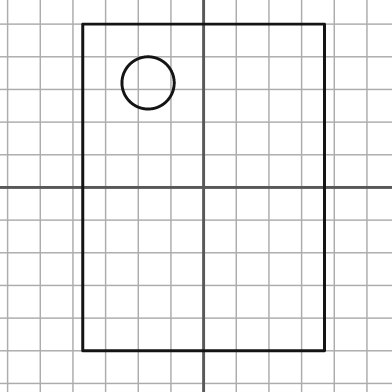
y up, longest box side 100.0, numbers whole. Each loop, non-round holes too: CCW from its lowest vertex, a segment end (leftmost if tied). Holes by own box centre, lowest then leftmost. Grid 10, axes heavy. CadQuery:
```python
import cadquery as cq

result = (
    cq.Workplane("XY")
    .moveTo(-37.0, -50.0)
    .lineTo(37.0, -50.0)
    .lineTo(37.0, 50.0)
    .lineTo(-37.0, 50.0)
    .close()
    .moveTo(-17.0, 32.0)
    .circle(8.0)
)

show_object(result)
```